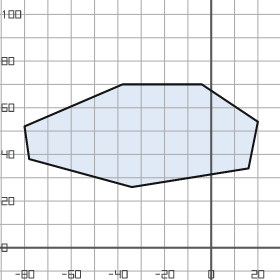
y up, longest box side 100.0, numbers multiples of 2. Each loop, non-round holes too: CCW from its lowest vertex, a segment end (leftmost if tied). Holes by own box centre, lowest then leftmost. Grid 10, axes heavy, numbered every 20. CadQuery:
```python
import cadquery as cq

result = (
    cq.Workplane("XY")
    .moveTo(-34.0, 26.0)
    .lineTo(16.0, 34.0)
    .lineTo(20.0, 54.0)
    .lineTo(-4.0, 70.0)
    .lineTo(-38.0, 70.0)
    .lineTo(-80.0, 52.0)
    .lineTo(-78.0, 38.0)
    .close()
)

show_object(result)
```